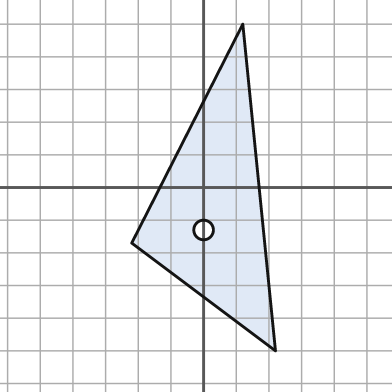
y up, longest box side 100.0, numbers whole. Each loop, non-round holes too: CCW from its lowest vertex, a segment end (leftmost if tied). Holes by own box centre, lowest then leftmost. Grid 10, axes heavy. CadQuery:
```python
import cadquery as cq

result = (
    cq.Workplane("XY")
    .moveTo(22.0, -50.0)
    .lineTo(12.0, 50.0)
    .lineTo(-22.0, -17.0)
    .close()
    .moveTo(0.0, -13.0)
    .circle(3.0)
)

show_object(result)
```